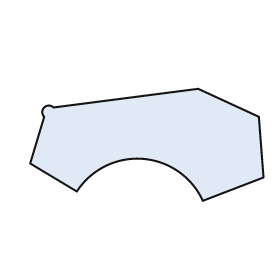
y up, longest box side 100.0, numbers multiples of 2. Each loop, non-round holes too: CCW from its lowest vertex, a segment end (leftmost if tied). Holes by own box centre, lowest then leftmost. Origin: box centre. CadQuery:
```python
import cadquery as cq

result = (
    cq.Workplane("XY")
    .moveTo(24.0, -24.0)
    .lineTo(50.0, -14.0)
    .lineTo(48.0, 12.0)
    .lineTo(22.0, 24.0)
    .lineTo(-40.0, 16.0)
    .threePointArc((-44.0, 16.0), (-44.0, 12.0))
    .lineTo(-50.0, -8.0)
    .lineTo(-30.0, -20.0)
    .threePointArc((-2.0, -6.0), (24.0, -24.0))
    .close()
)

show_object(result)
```